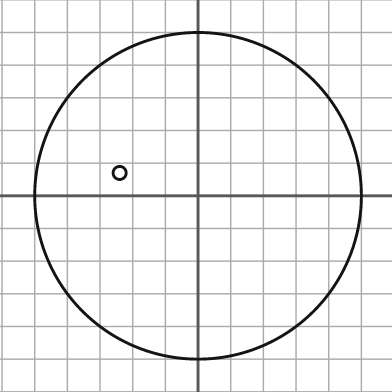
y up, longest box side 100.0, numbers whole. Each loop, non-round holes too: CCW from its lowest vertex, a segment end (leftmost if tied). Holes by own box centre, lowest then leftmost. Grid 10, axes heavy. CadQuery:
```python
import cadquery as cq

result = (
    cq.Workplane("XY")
    .moveTo(0.0, 0.0)
    .circle(50.0)
    .moveTo(-24.0, 7.0)
    .circle(2.0)
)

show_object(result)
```